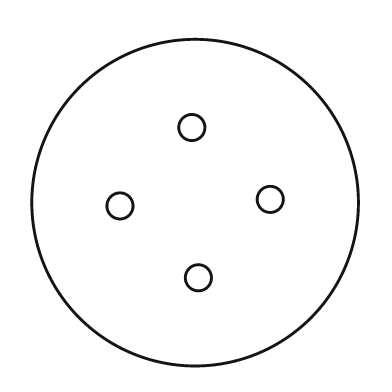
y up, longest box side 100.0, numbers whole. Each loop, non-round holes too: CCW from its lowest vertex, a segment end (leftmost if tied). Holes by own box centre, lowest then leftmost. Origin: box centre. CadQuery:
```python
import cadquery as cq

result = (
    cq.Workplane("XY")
    .moveTo(0.0, 0.0)
    .circle(50.0)
    .moveTo(1.0, -23.0)
    .circle(4.0)
    .moveTo(-23.0, -1.0)
    .circle(4.0)
    .moveTo(23.0, 1.0)
    .circle(4.0)
    .moveTo(-1.0, 23.0)
    .circle(4.0)
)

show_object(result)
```